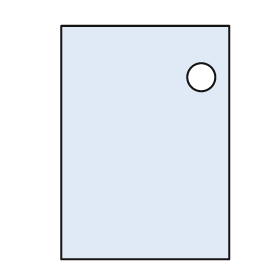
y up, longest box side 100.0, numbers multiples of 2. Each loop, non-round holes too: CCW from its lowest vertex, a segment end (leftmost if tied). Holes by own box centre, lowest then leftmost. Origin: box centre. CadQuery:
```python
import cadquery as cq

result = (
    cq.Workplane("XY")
    .moveTo(-36.0, -50.0)
    .lineTo(36.0, -50.0)
    .lineTo(36.0, 50.0)
    .lineTo(-36.0, 50.0)
    .close()
    .moveTo(24.0, 28.0)
    .circle(6.0)
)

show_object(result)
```